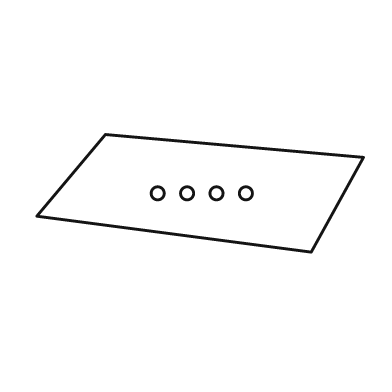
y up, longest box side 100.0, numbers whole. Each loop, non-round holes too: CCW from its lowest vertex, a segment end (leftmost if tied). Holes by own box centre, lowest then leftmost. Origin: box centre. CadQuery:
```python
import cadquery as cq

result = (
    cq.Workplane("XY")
    .moveTo(34.0, -18.0)
    .lineTo(50.0, 11.0)
    .lineTo(-29.0, 18.0)
    .lineTo(-50.0, -7.0)
    .close()
    .moveTo(-13.0, 0.0)
    .circle(2.0)
    .moveTo(-4.0, 0.0)
    .circle(2.0)
    .moveTo(5.0, 0.0)
    .circle(2.0)
    .moveTo(14.0, 0.0)
    .circle(2.0)
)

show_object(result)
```